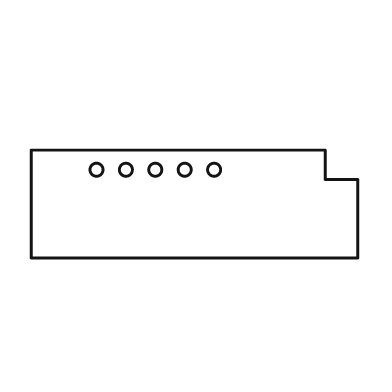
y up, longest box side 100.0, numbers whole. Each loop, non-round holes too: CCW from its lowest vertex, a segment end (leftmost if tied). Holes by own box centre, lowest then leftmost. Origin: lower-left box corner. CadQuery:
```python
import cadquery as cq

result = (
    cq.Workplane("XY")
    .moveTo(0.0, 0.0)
    .lineTo(100.0, 0.0)
    .lineTo(100.0, 24.0)
    .lineTo(90.0, 24.0)
    .lineTo(90.0, 33.0)
    .lineTo(0.0, 33.0)
    .close()
    .moveTo(20.0, 27.0)
    .circle(2.0)
    .moveTo(29.0, 27.0)
    .circle(2.0)
    .moveTo(38.0, 27.0)
    .circle(2.0)
    .moveTo(47.0, 27.0)
    .circle(2.0)
    .moveTo(56.0, 27.0)
    .circle(2.0)
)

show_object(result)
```